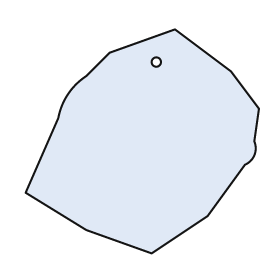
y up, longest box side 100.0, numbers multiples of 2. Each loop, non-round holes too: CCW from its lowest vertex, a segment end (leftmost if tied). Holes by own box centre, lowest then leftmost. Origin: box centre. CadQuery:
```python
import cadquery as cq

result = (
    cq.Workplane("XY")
    .moveTo(4.0, -48.0)
    .lineTo(28.0, -32.0)
    .lineTo(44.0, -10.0)
    .threePointArc((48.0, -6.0), (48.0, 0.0))
    .lineTo(50.0, 14.0)
    .lineTo(38.0, 30.0)
    .lineTo(14.0, 48.0)
    .lineTo(-14.0, 38.0)
    .lineTo(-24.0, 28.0)
    .threePointArc((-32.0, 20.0), (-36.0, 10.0))
    .lineTo(-50.0, -22.0)
    .lineTo(-24.0, -38.0)
    .close()
    .moveTo(6.0, 34.0)
    .circle(2.0)
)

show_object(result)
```